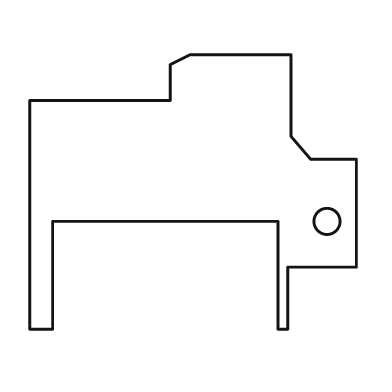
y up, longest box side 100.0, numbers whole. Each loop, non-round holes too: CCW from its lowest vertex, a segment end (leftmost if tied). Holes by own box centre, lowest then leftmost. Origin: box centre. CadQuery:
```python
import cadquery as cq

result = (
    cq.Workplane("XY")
    .moveTo(-50.0, -42.0)
    .lineTo(-43.0, -42.0)
    .lineTo(-43.0, -9.0)
    .lineTo(26.0, -9.0)
    .lineTo(26.0, -42.0)
    .lineTo(29.0, -42.0)
    .lineTo(29.0, -23.0)
    .lineTo(50.0, -23.0)
    .lineTo(50.0, 10.0)
    .lineTo(36.0, 10.0)
    .lineTo(30.0, 17.0)
    .lineTo(30.0, 42.0)
    .lineTo(-1.0, 42.0)
    .lineTo(-7.0, 39.0)
    .lineTo(-7.0, 28.0)
    .lineTo(-50.0, 28.0)
    .close()
    .moveTo(41.0, -9.0)
    .circle(4.0)
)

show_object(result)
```